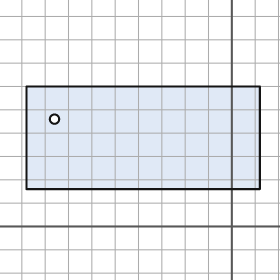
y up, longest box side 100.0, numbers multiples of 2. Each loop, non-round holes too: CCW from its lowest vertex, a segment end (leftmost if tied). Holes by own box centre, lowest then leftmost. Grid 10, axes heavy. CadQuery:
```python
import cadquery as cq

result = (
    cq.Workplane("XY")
    .moveTo(-88.0, 16.0)
    .lineTo(12.0, 16.0)
    .lineTo(12.0, 60.0)
    .lineTo(-88.0, 60.0)
    .close()
    .moveTo(-76.0, 46.0)
    .circle(2.0)
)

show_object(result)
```